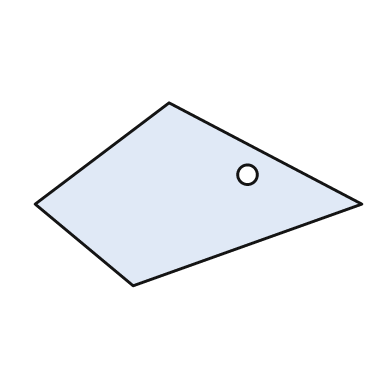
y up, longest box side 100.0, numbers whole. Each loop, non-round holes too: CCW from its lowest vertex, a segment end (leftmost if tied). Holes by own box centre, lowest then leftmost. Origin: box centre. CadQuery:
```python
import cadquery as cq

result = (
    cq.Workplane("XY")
    .moveTo(-20.0, -28.0)
    .lineTo(50.0, -3.0)
    .lineTo(-9.0, 28.0)
    .lineTo(-50.0, -3.0)
    .close()
    .moveTo(15.0, 6.0)
    .circle(3.0)
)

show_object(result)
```